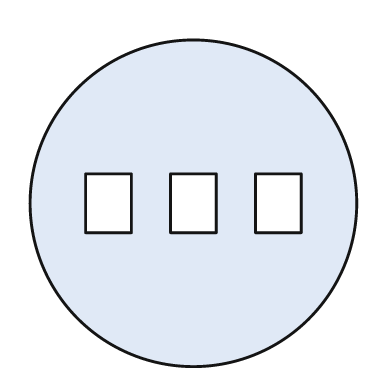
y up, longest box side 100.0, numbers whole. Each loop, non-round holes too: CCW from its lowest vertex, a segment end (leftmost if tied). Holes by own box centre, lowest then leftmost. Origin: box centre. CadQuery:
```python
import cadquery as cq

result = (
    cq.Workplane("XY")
    .moveTo(0.0, 0.0)
    .circle(50.0)
    .moveTo(-33.0, -9.0)
    .lineTo(-19.0, -9.0)
    .lineTo(-19.0, 9.0)
    .lineTo(-33.0, 9.0)
    .close()
    .moveTo(-7.0, -9.0)
    .lineTo(7.0, -9.0)
    .lineTo(7.0, 9.0)
    .lineTo(-7.0, 9.0)
    .close()
    .moveTo(19.0, -9.0)
    .lineTo(33.0, -9.0)
    .lineTo(33.0, 9.0)
    .lineTo(19.0, 9.0)
    .close()
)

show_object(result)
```